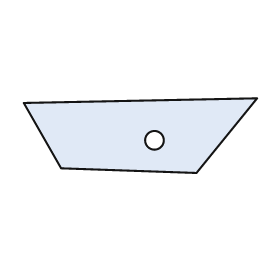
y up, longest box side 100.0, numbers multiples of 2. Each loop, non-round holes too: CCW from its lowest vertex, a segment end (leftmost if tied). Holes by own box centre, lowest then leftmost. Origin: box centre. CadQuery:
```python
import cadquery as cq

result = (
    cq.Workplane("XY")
    .moveTo(24.0, -16.0)
    .lineTo(50.0, 16.0)
    .lineTo(-50.0, 14.0)
    .lineTo(-34.0, -14.0)
    .close()
    .moveTo(6.0, -2.0)
    .circle(4.0)
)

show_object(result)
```